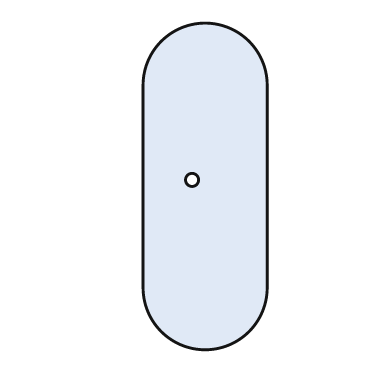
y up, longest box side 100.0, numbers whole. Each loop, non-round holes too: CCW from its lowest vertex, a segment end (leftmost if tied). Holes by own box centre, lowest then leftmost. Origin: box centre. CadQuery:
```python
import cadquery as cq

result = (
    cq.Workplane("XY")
    .moveTo(-19.0, -31.0)
    .threePointArc((0.0, -50.0), (19.0, -31.0))
    .lineTo(19.0, 31.0)
    .threePointArc((0.0, 50.0), (-19.0, 31.0))
    .close()
    .moveTo(-4.0, 2.0)
    .circle(2.0)
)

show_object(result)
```